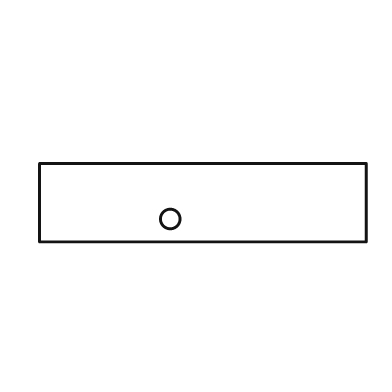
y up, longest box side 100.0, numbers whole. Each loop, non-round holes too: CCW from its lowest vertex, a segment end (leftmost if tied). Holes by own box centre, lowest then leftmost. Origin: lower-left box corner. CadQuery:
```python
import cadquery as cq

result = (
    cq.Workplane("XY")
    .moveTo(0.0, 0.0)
    .lineTo(100.0, 0.0)
    .lineTo(100.0, 24.0)
    .lineTo(0.0, 24.0)
    .close()
    .moveTo(40.0, 7.0)
    .circle(3.0)
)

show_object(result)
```